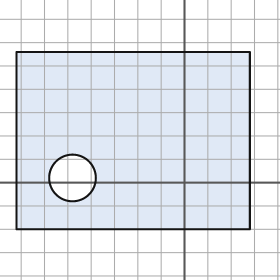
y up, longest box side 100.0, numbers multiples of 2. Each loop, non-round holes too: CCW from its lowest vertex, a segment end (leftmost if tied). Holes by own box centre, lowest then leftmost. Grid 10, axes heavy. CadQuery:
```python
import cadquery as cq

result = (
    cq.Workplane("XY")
    .moveTo(-72.0, -20.0)
    .lineTo(28.0, -20.0)
    .lineTo(28.0, 56.0)
    .lineTo(-72.0, 56.0)
    .close()
    .moveTo(-48.0, 2.0)
    .circle(10.0)
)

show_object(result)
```